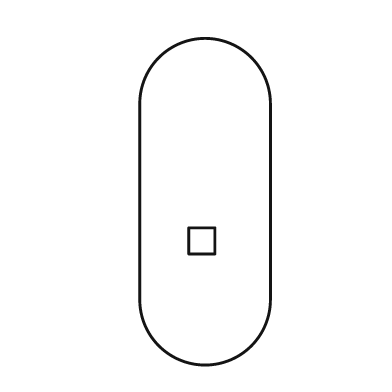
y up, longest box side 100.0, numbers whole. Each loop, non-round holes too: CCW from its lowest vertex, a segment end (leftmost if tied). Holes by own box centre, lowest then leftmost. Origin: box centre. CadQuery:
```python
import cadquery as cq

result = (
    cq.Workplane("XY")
    .moveTo(-20.0, -30.0)
    .threePointArc((0.0, -50.0), (20.0, -30.0))
    .lineTo(20.0, 30.0)
    .threePointArc((0.0, 50.0), (-20.0, 30.0))
    .close()
    .moveTo(-5.0, -16.0)
    .lineTo(3.0, -16.0)
    .lineTo(3.0, -8.0)
    .lineTo(-5.0, -8.0)
    .close()
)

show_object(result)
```